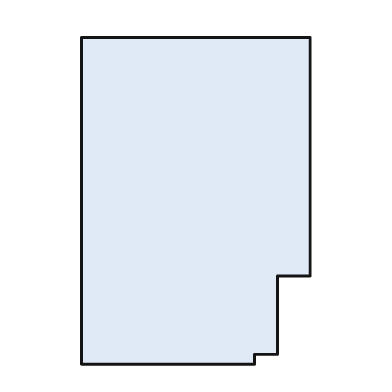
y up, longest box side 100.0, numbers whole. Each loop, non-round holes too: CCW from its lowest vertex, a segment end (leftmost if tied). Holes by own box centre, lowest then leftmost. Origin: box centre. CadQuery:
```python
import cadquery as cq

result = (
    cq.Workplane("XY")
    .moveTo(-35.0, -50.0)
    .lineTo(18.0, -50.0)
    .lineTo(18.0, -47.0)
    .lineTo(25.0, -47.0)
    .lineTo(25.0, -23.0)
    .lineTo(35.0, -23.0)
    .lineTo(35.0, 50.0)
    .lineTo(-35.0, 50.0)
    .close()
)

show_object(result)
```